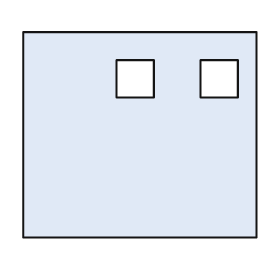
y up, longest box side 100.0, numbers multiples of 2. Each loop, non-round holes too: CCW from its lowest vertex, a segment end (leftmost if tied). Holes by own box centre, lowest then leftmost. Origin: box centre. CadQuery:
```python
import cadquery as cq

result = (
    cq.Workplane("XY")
    .moveTo(-50.0, -44.0)
    .lineTo(50.0, -44.0)
    .lineTo(50.0, 44.0)
    .lineTo(-50.0, 44.0)
    .close()
    .moveTo(-10.0, 16.0)
    .lineTo(6.0, 16.0)
    .lineTo(6.0, 32.0)
    .lineTo(-10.0, 32.0)
    .close()
    .moveTo(26.0, 16.0)
    .lineTo(42.0, 16.0)
    .lineTo(42.0, 32.0)
    .lineTo(26.0, 32.0)
    .close()
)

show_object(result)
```